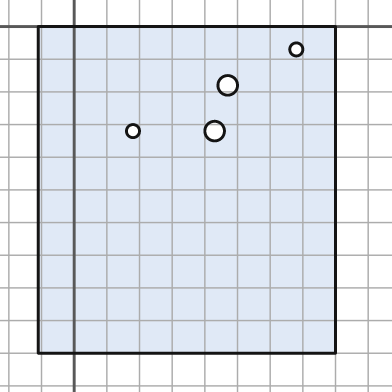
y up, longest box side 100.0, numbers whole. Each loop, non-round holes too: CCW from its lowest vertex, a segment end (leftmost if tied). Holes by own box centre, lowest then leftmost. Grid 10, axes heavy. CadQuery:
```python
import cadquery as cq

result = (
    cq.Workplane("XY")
    .moveTo(-11.0, -100.0)
    .lineTo(80.0, -100.0)
    .lineTo(80.0, 0.0)
    .lineTo(-11.0, 0.0)
    .close()
    .moveTo(18.0, -32.0)
    .circle(2.0)
    .moveTo(43.0, -32.0)
    .circle(3.0)
    .moveTo(47.0, -18.0)
    .circle(3.0)
    .moveTo(68.0, -7.0)
    .circle(2.0)
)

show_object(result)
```